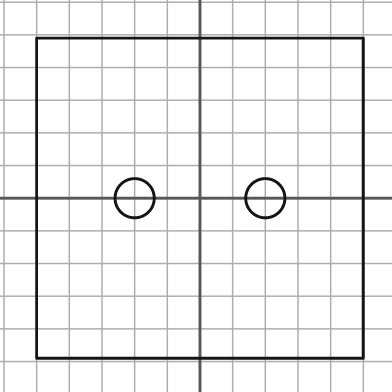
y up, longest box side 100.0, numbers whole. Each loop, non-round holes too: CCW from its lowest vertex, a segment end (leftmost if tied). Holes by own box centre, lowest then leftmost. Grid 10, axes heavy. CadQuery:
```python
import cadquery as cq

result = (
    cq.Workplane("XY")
    .moveTo(-50.0, -49.0)
    .lineTo(50.0, -49.0)
    .lineTo(50.0, 49.0)
    .lineTo(-50.0, 49.0)
    .close()
    .moveTo(-20.0, 0.0)
    .circle(6.0)
    .moveTo(20.0, 0.0)
    .circle(6.0)
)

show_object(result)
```